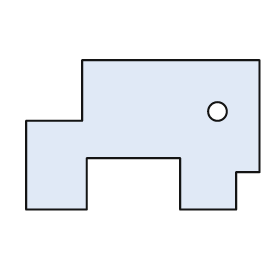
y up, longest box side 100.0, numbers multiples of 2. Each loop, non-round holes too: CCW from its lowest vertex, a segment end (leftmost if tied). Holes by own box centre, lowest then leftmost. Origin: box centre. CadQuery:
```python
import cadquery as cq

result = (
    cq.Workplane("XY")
    .moveTo(-50.0, -32.0)
    .lineTo(-24.0, -32.0)
    .lineTo(-24.0, -10.0)
    .lineTo(16.0, -10.0)
    .lineTo(16.0, -32.0)
    .lineTo(40.0, -32.0)
    .lineTo(40.0, -16.0)
    .lineTo(50.0, -16.0)
    .lineTo(50.0, 32.0)
    .lineTo(-26.0, 32.0)
    .lineTo(-26.0, 6.0)
    .lineTo(-50.0, 6.0)
    .close()
    .moveTo(32.0, 10.0)
    .circle(4.0)
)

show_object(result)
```